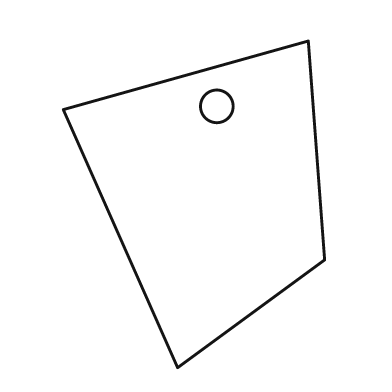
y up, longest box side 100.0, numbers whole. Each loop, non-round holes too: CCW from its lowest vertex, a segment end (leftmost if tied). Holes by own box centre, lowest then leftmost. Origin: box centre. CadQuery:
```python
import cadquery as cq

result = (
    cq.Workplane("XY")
    .moveTo(-5.0, -50.0)
    .lineTo(40.0, -17.0)
    .lineTo(35.0, 50.0)
    .lineTo(-40.0, 29.0)
    .close()
    .moveTo(7.0, 30.0)
    .circle(5.0)
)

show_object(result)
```